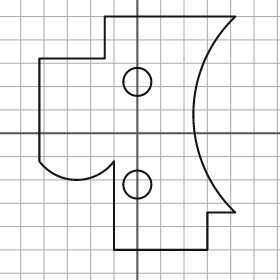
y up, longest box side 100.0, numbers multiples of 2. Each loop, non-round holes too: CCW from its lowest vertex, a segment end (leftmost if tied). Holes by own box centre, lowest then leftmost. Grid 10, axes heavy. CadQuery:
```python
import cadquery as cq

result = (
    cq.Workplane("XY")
    .moveTo(-10.0, -50.0)
    .lineTo(30.0, -50.0)
    .lineTo(30.0, -34.0)
    .lineTo(42.0, -34.0)
    .threePointArc((24.0, 8.0), (42.0, 50.0))
    .lineTo(-14.0, 50.0)
    .lineTo(-14.0, 32.0)
    .lineTo(-42.0, 32.0)
    .lineTo(-42.0, -12.0)
    .threePointArc((-26.0, -20.0), (-10.0, -12.0))
    .close()
    .moveTo(0.0, -22.0)
    .circle(6.0)
    .moveTo(0.0, 22.0)
    .circle(6.0)
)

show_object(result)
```